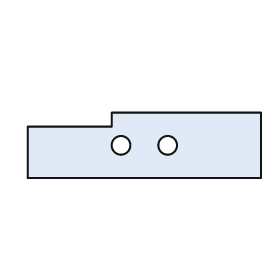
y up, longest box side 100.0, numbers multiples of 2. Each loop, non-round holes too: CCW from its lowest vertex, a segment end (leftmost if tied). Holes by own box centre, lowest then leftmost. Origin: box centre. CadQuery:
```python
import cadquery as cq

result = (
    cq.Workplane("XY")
    .moveTo(-50.0, -14.0)
    .lineTo(50.0, -14.0)
    .lineTo(50.0, 14.0)
    .lineTo(-14.0, 14.0)
    .lineTo(-14.0, 8.0)
    .lineTo(-50.0, 8.0)
    .close()
    .moveTo(-10.0, 0.0)
    .circle(4.0)
    .moveTo(10.0, 0.0)
    .circle(4.0)
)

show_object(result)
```